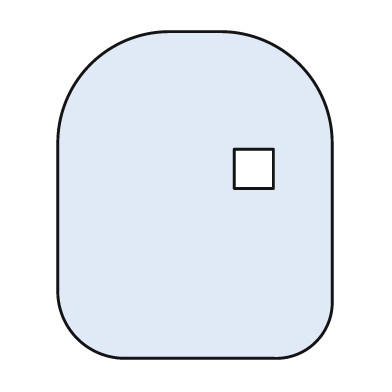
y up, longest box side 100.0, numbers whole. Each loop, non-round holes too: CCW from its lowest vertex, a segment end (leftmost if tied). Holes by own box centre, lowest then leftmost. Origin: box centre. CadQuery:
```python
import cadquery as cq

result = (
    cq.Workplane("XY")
    .moveTo(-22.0, -50.0)
    .lineTo(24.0, -50.0)
    .threePointArc((37.0, -45.0), (42.0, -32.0))
    .lineTo(42.0, 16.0)
    .threePointArc((32.0, 40.0), (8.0, 50.0))
    .lineTo(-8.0, 50.0)
    .threePointArc((-32.0, 40.0), (-42.0, 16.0))
    .lineTo(-42.0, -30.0)
    .threePointArc((-36.0, -44.0), (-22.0, -50.0))
    .close()
    .moveTo(12.0, 2.0)
    .lineTo(24.0, 2.0)
    .lineTo(24.0, 14.0)
    .lineTo(12.0, 14.0)
    .close()
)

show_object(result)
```